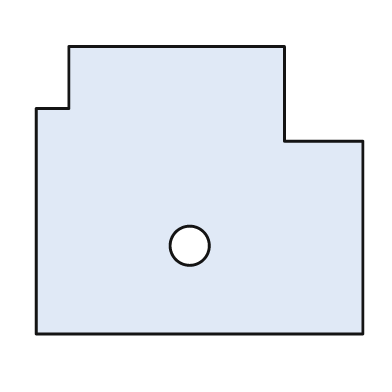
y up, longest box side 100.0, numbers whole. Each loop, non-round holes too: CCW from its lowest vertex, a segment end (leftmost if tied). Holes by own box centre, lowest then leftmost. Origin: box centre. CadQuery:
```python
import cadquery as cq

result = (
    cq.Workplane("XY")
    .moveTo(-50.0, -44.0)
    .lineTo(50.0, -44.0)
    .lineTo(50.0, 15.0)
    .lineTo(26.0, 15.0)
    .lineTo(26.0, 44.0)
    .lineTo(-40.0, 44.0)
    .lineTo(-40.0, 25.0)
    .lineTo(-50.0, 25.0)
    .close()
    .moveTo(-3.0, -17.0)
    .circle(6.0)
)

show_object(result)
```